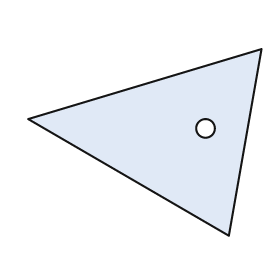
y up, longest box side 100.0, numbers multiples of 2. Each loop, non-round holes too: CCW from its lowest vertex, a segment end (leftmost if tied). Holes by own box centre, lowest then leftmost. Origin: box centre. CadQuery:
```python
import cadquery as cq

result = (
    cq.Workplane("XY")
    .moveTo(36.0, -40.0)
    .lineTo(50.0, 40.0)
    .lineTo(-50.0, 10.0)
    .close()
    .moveTo(26.0, 6.0)
    .circle(4.0)
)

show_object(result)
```